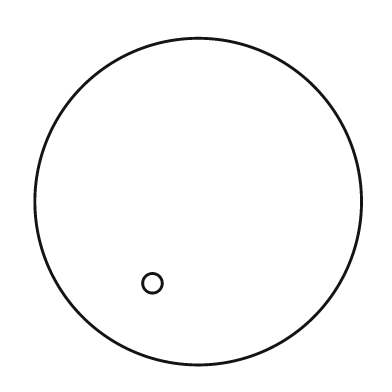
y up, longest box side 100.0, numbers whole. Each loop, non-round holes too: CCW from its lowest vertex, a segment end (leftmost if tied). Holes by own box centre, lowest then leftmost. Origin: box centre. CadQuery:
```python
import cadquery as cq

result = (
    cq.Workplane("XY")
    .moveTo(0.0, 0.0)
    .circle(50.0)
    .moveTo(-14.0, -25.0)
    .circle(3.0)
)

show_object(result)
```